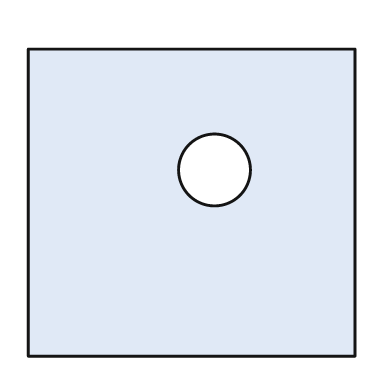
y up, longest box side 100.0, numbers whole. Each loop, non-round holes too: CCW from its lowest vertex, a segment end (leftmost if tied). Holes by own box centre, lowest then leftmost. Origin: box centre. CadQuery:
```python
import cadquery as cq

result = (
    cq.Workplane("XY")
    .moveTo(-50.0, -47.0)
    .lineTo(50.0, -47.0)
    .lineTo(50.0, 47.0)
    .lineTo(-50.0, 47.0)
    .close()
    .moveTo(7.0, 10.0)
    .circle(11.0)
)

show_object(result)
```